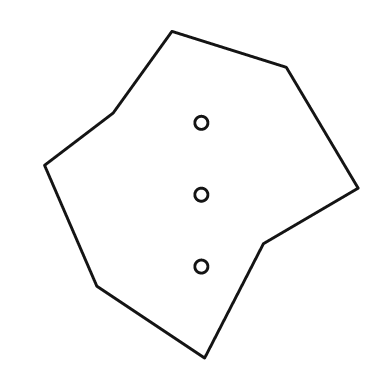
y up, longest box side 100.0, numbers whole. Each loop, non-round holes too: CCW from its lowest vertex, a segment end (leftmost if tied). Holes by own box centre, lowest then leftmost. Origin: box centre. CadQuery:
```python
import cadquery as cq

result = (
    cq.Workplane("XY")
    .moveTo(1.0, -50.0)
    .lineTo(19.0, -15.0)
    .lineTo(48.0, 2.0)
    .lineTo(26.0, 39.0)
    .lineTo(-9.0, 50.0)
    .lineTo(-27.0, 25.0)
    .lineTo(-48.0, 9.0)
    .lineTo(-32.0, -28.0)
    .close()
    .moveTo(0.0, -22.0)
    .circle(2.0)
    .moveTo(0.0, 0.0)
    .circle(2.0)
    .moveTo(0.0, 22.0)
    .circle(2.0)
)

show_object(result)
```